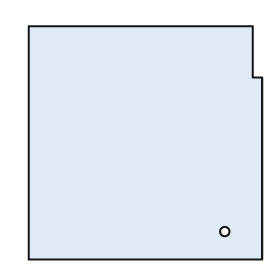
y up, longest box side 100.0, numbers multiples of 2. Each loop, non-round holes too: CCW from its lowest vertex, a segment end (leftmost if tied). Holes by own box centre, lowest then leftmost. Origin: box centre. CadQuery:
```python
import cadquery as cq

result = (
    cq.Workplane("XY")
    .moveTo(-50.0, -50.0)
    .lineTo(50.0, -50.0)
    .lineTo(50.0, 28.0)
    .lineTo(46.0, 28.0)
    .lineTo(46.0, 50.0)
    .lineTo(-50.0, 50.0)
    .close()
    .moveTo(34.0, -38.0)
    .circle(2.0)
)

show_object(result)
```